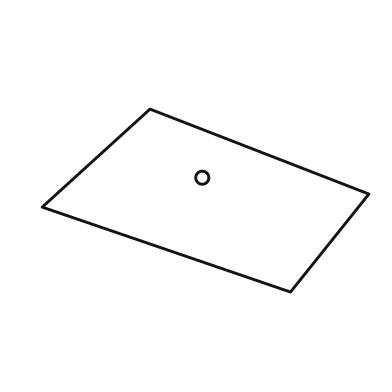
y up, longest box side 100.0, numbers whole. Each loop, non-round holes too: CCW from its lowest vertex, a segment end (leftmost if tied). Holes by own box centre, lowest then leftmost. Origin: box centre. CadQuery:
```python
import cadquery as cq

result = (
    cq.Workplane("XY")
    .moveTo(26.0, -28.0)
    .lineTo(50.0, 2.0)
    .lineTo(-17.0, 28.0)
    .lineTo(-50.0, -2.0)
    .close()
    .moveTo(-1.0, 7.0)
    .circle(2.0)
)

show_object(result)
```